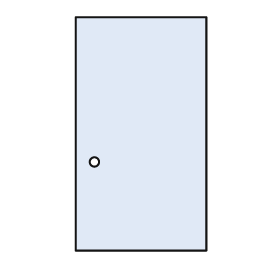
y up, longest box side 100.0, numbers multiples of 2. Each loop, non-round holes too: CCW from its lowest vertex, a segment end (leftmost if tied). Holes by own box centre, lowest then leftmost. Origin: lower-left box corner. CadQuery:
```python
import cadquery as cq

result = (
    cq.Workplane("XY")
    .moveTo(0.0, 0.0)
    .lineTo(56.0, 0.0)
    .lineTo(56.0, 100.0)
    .lineTo(0.0, 100.0)
    .close()
    .moveTo(8.0, 38.0)
    .circle(2.0)
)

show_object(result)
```